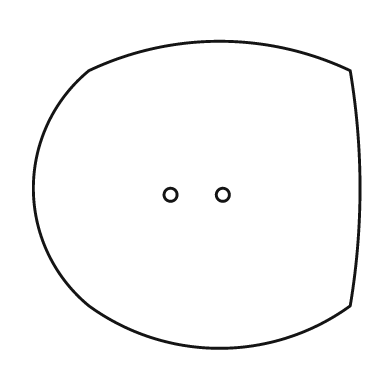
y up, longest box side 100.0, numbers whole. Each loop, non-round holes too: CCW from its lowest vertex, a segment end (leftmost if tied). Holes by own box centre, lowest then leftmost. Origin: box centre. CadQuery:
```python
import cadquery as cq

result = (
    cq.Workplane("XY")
    .moveTo(-33.0, -34.0)
    .threePointArc((7.0, -47.0), (47.0, -34.0))
    .threePointArc((50.0, 2.0), (47.0, 38.0))
    .threePointArc((7.0, 47.0), (-33.0, 38.0))
    .threePointArc((-50.0, 2.0), (-33.0, -34.0))
    .close()
    .moveTo(-8.0, 0.0)
    .circle(2.0)
    .moveTo(8.0, 0.0)
    .circle(2.0)
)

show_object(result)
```